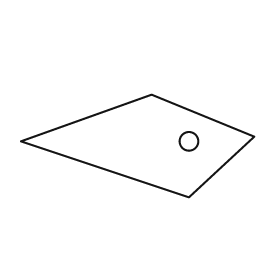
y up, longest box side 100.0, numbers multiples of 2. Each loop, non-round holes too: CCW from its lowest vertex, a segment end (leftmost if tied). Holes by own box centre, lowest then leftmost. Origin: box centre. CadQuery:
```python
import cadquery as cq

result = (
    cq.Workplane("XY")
    .moveTo(22.0, -22.0)
    .lineTo(50.0, 4.0)
    .lineTo(6.0, 22.0)
    .lineTo(-50.0, 2.0)
    .close()
    .moveTo(22.0, 2.0)
    .circle(4.0)
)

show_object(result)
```